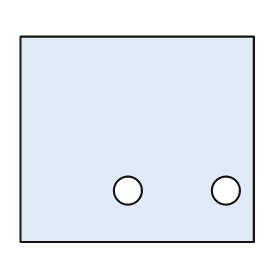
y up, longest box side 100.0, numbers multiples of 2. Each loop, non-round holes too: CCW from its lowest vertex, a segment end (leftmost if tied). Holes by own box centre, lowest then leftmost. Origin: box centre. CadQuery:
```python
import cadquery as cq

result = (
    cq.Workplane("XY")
    .moveTo(-50.0, -44.0)
    .lineTo(50.0, -44.0)
    .lineTo(50.0, 44.0)
    .lineTo(-50.0, 44.0)
    .close()
    .moveTo(-4.0, -22.0)
    .circle(6.0)
    .moveTo(38.0, -22.0)
    .circle(6.0)
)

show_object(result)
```